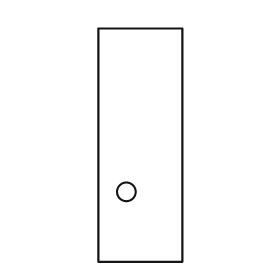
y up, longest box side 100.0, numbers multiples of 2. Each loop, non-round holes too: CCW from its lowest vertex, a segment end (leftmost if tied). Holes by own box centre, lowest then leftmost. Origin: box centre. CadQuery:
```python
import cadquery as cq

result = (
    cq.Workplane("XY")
    .moveTo(-18.0, -50.0)
    .lineTo(18.0, -50.0)
    .lineTo(18.0, 50.0)
    .lineTo(-18.0, 50.0)
    .close()
    .moveTo(-6.0, -20.0)
    .circle(4.0)
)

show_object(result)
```